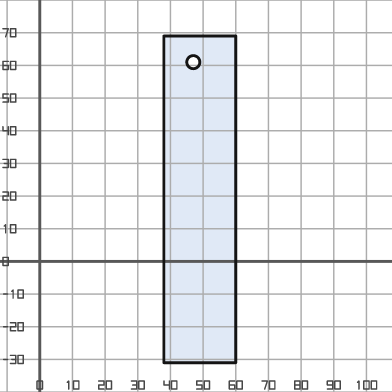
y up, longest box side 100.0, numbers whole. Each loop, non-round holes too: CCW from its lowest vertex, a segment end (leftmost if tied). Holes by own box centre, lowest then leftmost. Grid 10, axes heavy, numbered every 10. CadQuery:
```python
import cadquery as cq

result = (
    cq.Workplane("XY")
    .moveTo(38.0, -31.0)
    .lineTo(60.0, -31.0)
    .lineTo(60.0, 69.0)
    .lineTo(38.0, 69.0)
    .close()
    .moveTo(47.0, 61.0)
    .circle(2.0)
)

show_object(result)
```